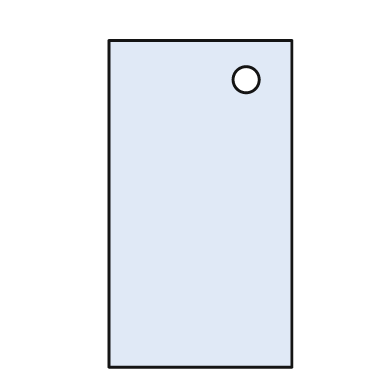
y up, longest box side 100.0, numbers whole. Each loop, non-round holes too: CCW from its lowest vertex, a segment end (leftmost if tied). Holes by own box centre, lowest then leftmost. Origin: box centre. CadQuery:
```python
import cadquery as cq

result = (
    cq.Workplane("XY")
    .moveTo(-28.0, -50.0)
    .lineTo(28.0, -50.0)
    .lineTo(28.0, 50.0)
    .lineTo(-28.0, 50.0)
    .close()
    .moveTo(14.0, 38.0)
    .circle(4.0)
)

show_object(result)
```